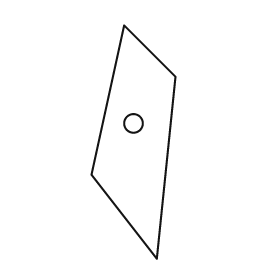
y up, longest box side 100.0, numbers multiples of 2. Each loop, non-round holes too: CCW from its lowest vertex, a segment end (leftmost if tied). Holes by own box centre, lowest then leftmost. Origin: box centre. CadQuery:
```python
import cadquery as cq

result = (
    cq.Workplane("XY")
    .moveTo(10.0, -50.0)
    .lineTo(18.0, 28.0)
    .lineTo(-4.0, 50.0)
    .lineTo(-18.0, -14.0)
    .close()
    .moveTo(0.0, 8.0)
    .circle(4.0)
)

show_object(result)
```